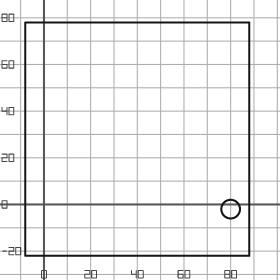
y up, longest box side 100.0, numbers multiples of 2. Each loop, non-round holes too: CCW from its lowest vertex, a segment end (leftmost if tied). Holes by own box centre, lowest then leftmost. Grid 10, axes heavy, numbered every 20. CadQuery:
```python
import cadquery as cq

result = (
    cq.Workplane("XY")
    .moveTo(-8.0, -22.0)
    .lineTo(88.0, -22.0)
    .lineTo(88.0, 78.0)
    .lineTo(-8.0, 78.0)
    .close()
    .moveTo(80.0, -2.0)
    .circle(4.0)
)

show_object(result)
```